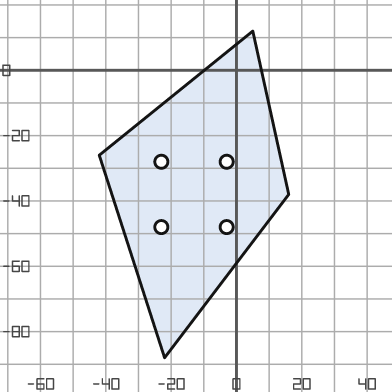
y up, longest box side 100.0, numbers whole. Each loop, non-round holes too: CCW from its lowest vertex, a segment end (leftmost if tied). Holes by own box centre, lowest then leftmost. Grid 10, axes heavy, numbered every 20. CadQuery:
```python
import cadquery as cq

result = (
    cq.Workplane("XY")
    .moveTo(-22.0, -88.0)
    .lineTo(16.0, -38.0)
    .lineTo(5.0, 12.0)
    .lineTo(-42.0, -26.0)
    .close()
    .moveTo(-23.0, -48.0)
    .circle(2.0)
    .moveTo(-3.0, -48.0)
    .circle(2.0)
    .moveTo(-23.0, -28.0)
    .circle(2.0)
    .moveTo(-3.0, -28.0)
    .circle(2.0)
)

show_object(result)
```